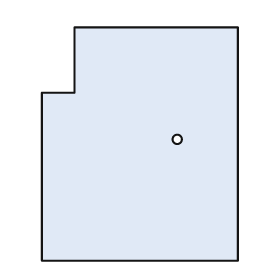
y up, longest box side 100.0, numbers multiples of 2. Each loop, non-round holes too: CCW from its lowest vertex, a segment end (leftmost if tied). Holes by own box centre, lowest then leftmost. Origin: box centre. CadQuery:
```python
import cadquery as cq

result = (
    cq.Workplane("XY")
    .moveTo(-42.0, -50.0)
    .lineTo(42.0, -50.0)
    .lineTo(42.0, 50.0)
    .lineTo(-28.0, 50.0)
    .lineTo(-28.0, 22.0)
    .lineTo(-42.0, 22.0)
    .close()
    .moveTo(16.0, 2.0)
    .circle(2.0)
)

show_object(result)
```